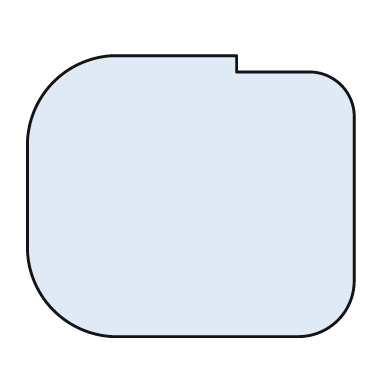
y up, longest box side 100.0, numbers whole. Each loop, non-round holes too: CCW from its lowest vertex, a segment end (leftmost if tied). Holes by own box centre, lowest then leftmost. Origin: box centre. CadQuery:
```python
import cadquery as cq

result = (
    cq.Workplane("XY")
    .moveTo(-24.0, -43.0)
    .lineTo(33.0, -43.0)
    .threePointArc((45.0, -38.0), (50.0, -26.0))
    .lineTo(50.0, 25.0)
    .threePointArc((46.0, 34.0), (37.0, 38.0))
    .lineTo(14.0, 38.0)
    .lineTo(14.0, 43.0)
    .lineTo(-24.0, 43.0)
    .threePointArc((-42.0, 35.0), (-50.0, 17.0))
    .lineTo(-50.0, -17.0)
    .threePointArc((-42.0, -35.0), (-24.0, -43.0))
    .close()
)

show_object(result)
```